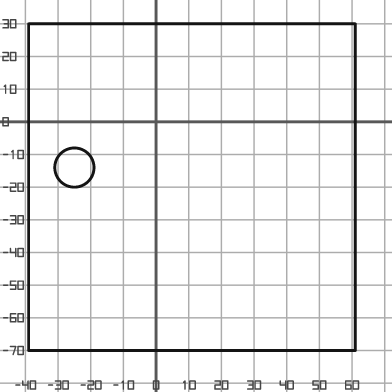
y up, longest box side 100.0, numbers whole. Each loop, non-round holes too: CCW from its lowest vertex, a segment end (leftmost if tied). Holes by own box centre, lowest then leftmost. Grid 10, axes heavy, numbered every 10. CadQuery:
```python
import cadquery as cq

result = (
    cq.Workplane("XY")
    .moveTo(-39.0, -70.0)
    .lineTo(61.0, -70.0)
    .lineTo(61.0, 30.0)
    .lineTo(-39.0, 30.0)
    .close()
    .moveTo(-25.0, -14.0)
    .circle(6.0)
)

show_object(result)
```